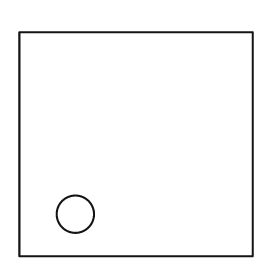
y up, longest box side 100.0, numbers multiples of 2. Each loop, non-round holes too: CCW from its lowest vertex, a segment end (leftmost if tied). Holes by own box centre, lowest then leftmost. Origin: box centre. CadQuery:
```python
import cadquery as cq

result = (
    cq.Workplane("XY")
    .moveTo(-50.0, -48.0)
    .lineTo(50.0, -48.0)
    .lineTo(50.0, 48.0)
    .lineTo(-50.0, 48.0)
    .close()
    .moveTo(-26.0, -30.0)
    .circle(8.0)
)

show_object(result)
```